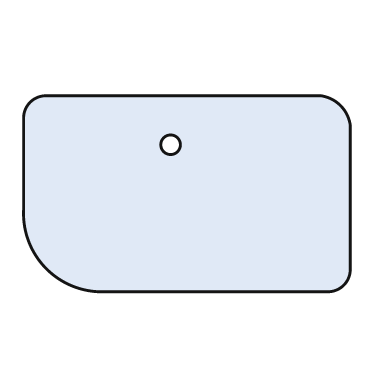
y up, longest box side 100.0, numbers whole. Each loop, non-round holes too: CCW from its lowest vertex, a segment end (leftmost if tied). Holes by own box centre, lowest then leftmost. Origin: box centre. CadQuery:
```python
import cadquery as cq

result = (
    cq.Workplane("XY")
    .moveTo(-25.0, -30.0)
    .lineTo(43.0, -30.0)
    .threePointArc((48.0, -28.0), (50.0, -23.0))
    .lineTo(50.0, 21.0)
    .threePointArc((47.0, 27.0), (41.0, 30.0))
    .lineTo(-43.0, 30.0)
    .threePointArc((-48.0, 28.0), (-50.0, 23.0))
    .lineTo(-50.0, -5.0)
    .threePointArc((-43.0, -23.0), (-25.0, -30.0))
    .close()
    .moveTo(-5.0, 15.0)
    .circle(3.0)
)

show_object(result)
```